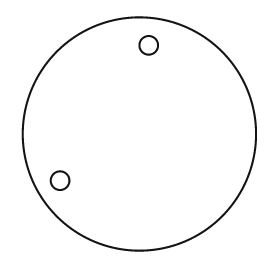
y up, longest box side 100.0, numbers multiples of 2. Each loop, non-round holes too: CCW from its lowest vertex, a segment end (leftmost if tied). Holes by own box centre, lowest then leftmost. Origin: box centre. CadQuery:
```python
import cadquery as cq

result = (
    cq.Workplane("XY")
    .moveTo(0.0, 0.0)
    .circle(50.0)
    .moveTo(-34.0, -20.0)
    .circle(4.0)
    .moveTo(4.0, 38.0)
    .circle(4.0)
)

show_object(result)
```